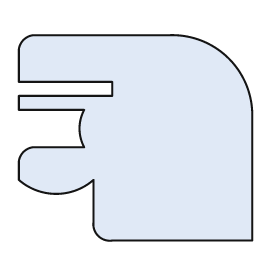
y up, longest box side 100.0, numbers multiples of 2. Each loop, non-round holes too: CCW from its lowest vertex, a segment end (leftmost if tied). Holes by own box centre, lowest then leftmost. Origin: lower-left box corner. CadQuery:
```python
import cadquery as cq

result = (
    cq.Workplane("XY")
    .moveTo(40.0, 0.0)
    .lineTo(100.0, 0.0)
    .lineTo(100.0, 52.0)
    .threePointArc((90.0, 78.0), (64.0, 88.0))
    .lineTo(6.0, 88.0)
    .threePointArc((2.0, 86.0), (0.0, 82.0))
    .lineTo(0.0, 68.0)
    .lineTo(40.0, 68.0)
    .lineTo(40.0, 62.0)
    .lineTo(0.0, 62.0)
    .lineTo(0.0, 56.0)
    .lineTo(28.0, 56.0)
    .threePointArc((26.0, 48.0), (28.0, 40.0))
    .lineTo(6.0, 40.0)
    .threePointArc((2.0, 38.0), (0.0, 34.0))
    .lineTo(0.0, 26.0)
    .threePointArc((16.0, 20.0), (32.0, 26.0))
    .lineTo(32.0, 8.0)
    .threePointArc((34.0, 2.0), (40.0, 0.0))
    .close()
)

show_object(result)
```